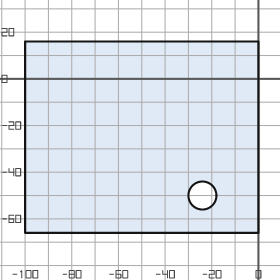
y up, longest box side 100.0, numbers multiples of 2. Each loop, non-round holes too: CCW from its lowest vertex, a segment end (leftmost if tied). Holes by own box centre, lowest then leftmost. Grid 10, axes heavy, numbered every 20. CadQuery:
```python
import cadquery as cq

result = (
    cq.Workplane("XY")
    .moveTo(-100.0, -66.0)
    .lineTo(0.0, -66.0)
    .lineTo(0.0, 16.0)
    .lineTo(-100.0, 16.0)
    .close()
    .moveTo(-24.0, -50.0)
    .circle(6.0)
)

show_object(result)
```